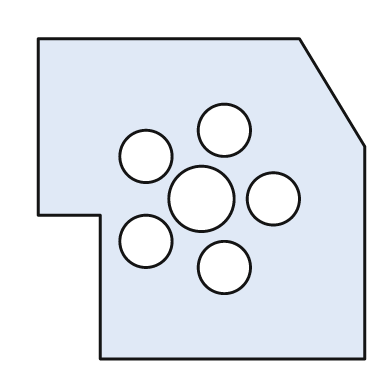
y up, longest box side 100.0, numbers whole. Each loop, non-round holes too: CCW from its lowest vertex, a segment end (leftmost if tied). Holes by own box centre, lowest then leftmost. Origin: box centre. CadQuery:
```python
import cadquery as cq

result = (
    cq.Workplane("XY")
    .moveTo(-31.0, -49.0)
    .lineTo(50.0, -49.0)
    .lineTo(50.0, 16.0)
    .lineTo(30.0, 49.0)
    .lineTo(-50.0, 49.0)
    .lineTo(-50.0, -5.0)
    .lineTo(-31.0, -5.0)
    .close()
    .moveTo(7.0, -21.0)
    .circle(8.0)
    .moveTo(-17.0, -13.0)
    .circle(8.0)
    .moveTo(0.0, 0.0)
    .circle(10.0)
    .moveTo(22.0, 0.0)
    .circle(8.0)
    .moveTo(-17.0, 13.0)
    .circle(8.0)
    .moveTo(7.0, 21.0)
    .circle(8.0)
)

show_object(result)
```